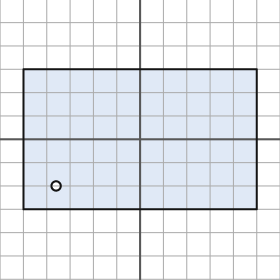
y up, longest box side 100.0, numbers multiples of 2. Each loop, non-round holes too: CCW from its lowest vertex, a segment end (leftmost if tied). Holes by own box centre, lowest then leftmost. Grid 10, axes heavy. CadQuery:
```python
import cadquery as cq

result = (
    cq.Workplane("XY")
    .moveTo(-50.0, -30.0)
    .lineTo(50.0, -30.0)
    .lineTo(50.0, 30.0)
    .lineTo(-50.0, 30.0)
    .close()
    .moveTo(-36.0, -20.0)
    .circle(2.0)
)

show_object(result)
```